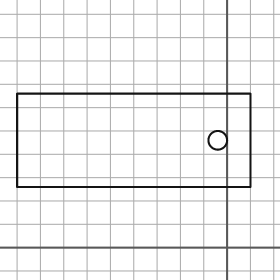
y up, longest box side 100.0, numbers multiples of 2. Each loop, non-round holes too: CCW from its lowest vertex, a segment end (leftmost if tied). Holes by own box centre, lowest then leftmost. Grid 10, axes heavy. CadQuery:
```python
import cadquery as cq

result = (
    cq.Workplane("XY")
    .moveTo(-90.0, 26.0)
    .lineTo(10.0, 26.0)
    .lineTo(10.0, 66.0)
    .lineTo(-90.0, 66.0)
    .close()
    .moveTo(-4.0, 46.0)
    .circle(4.0)
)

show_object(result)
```